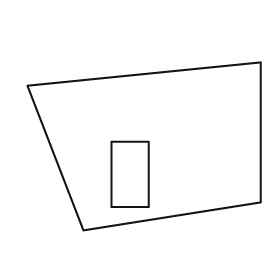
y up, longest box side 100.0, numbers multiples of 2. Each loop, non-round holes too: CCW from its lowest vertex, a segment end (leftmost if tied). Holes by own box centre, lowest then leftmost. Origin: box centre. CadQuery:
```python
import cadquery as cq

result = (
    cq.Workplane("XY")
    .moveTo(-26.0, -36.0)
    .lineTo(50.0, -24.0)
    .lineTo(50.0, 36.0)
    .lineTo(-50.0, 26.0)
    .close()
    .moveTo(-14.0, -26.0)
    .lineTo(2.0, -26.0)
    .lineTo(2.0, 2.0)
    .lineTo(-14.0, 2.0)
    .close()
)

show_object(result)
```